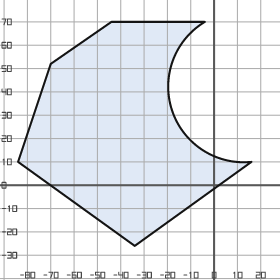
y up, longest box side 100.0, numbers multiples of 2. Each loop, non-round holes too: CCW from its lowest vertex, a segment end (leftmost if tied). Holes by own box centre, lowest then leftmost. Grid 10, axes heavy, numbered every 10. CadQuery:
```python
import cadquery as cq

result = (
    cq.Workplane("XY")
    .moveTo(-34.0, -26.0)
    .lineTo(16.0, 10.0)
    .threePointArc((-18.0, 32.0), (-4.0, 70.0))
    .lineTo(-44.0, 70.0)
    .lineTo(-70.0, 52.0)
    .lineTo(-84.0, 10.0)
    .close()
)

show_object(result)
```